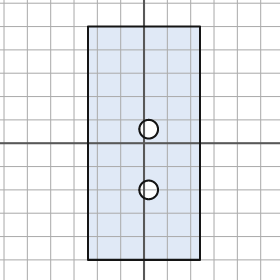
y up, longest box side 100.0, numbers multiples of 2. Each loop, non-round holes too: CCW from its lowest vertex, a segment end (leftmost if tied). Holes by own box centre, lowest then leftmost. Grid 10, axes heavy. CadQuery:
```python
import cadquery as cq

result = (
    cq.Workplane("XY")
    .moveTo(-24.0, -50.0)
    .lineTo(24.0, -50.0)
    .lineTo(24.0, 50.0)
    .lineTo(-24.0, 50.0)
    .close()
    .moveTo(2.0, -20.0)
    .circle(4.0)
    .moveTo(2.0, 6.0)
    .circle(4.0)
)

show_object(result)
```